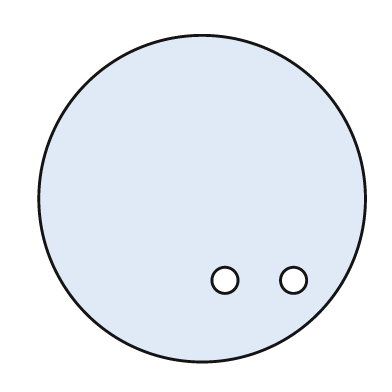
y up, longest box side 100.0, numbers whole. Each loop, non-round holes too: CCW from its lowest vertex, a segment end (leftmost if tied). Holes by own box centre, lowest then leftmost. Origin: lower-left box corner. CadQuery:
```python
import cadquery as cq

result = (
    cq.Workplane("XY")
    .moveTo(50.0, 50.0)
    .circle(50.0)
    .moveTo(57.0, 25.0)
    .circle(4.0)
    .moveTo(78.0, 25.0)
    .circle(4.0)
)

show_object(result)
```